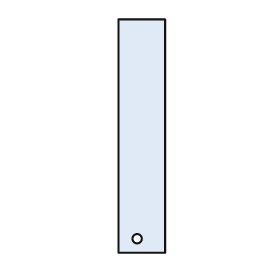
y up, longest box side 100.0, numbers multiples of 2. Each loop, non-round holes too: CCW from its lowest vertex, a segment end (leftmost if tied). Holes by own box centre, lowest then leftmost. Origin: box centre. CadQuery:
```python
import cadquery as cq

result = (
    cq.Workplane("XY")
    .moveTo(-10.0, -50.0)
    .lineTo(10.0, -50.0)
    .lineTo(10.0, 50.0)
    .lineTo(-10.0, 50.0)
    .close()
    .moveTo(-2.0, -44.0)
    .circle(2.0)
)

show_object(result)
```